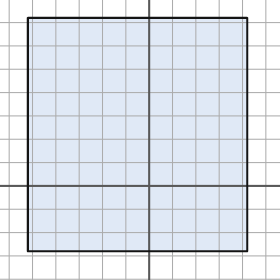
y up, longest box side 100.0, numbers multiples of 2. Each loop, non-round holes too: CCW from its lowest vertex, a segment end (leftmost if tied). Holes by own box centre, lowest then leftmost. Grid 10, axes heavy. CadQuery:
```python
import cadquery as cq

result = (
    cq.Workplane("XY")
    .moveTo(-52.0, -28.0)
    .lineTo(42.0, -28.0)
    .lineTo(42.0, 72.0)
    .lineTo(-52.0, 72.0)
    .close()
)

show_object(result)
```